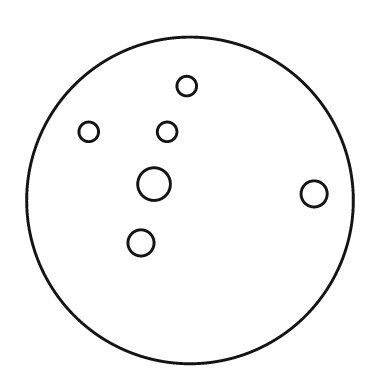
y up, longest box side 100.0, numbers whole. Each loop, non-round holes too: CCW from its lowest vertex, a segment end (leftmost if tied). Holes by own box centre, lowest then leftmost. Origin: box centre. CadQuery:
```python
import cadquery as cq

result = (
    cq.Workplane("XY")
    .moveTo(0.0, 0.0)
    .circle(50.0)
    .moveTo(-15.0, -13.0)
    .circle(4.0)
    .moveTo(38.0, 2.0)
    .circle(4.0)
    .moveTo(-11.0, 5.0)
    .circle(5.0)
    .moveTo(-31.0, 21.0)
    .circle(3.0)
    .moveTo(-7.0, 21.0)
    .circle(3.0)
    .moveTo(-1.0, 35.0)
    .circle(3.0)
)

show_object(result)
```